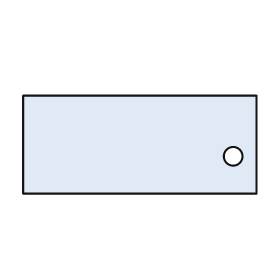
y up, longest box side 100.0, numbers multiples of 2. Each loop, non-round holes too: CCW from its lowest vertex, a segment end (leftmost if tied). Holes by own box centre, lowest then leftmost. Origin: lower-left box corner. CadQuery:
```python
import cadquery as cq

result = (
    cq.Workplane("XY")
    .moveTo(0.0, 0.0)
    .lineTo(100.0, 0.0)
    .lineTo(100.0, 42.0)
    .lineTo(0.0, 42.0)
    .close()
    .moveTo(90.0, 16.0)
    .circle(4.0)
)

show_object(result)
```